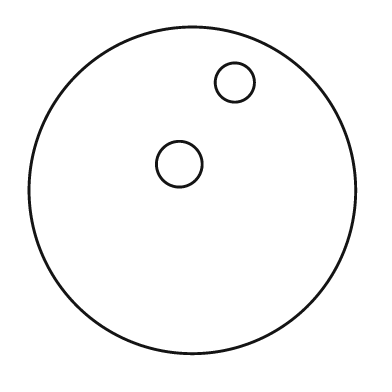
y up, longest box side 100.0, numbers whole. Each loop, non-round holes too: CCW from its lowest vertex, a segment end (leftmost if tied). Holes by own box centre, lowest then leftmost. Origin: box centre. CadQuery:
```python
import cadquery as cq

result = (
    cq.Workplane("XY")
    .moveTo(0.0, 0.0)
    .circle(50.0)
    .moveTo(-4.0, 8.0)
    .circle(7.0)
    .moveTo(13.0, 33.0)
    .circle(6.0)
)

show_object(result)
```